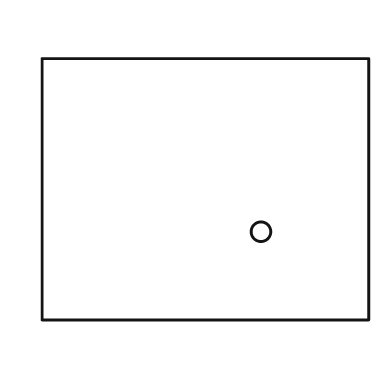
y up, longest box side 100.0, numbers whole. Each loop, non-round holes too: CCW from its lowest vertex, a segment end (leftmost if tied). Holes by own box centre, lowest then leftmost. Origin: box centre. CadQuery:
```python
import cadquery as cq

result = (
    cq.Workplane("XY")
    .moveTo(-50.0, -40.0)
    .lineTo(50.0, -40.0)
    .lineTo(50.0, 40.0)
    .lineTo(-50.0, 40.0)
    .close()
    .moveTo(17.0, -13.0)
    .circle(3.0)
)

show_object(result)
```